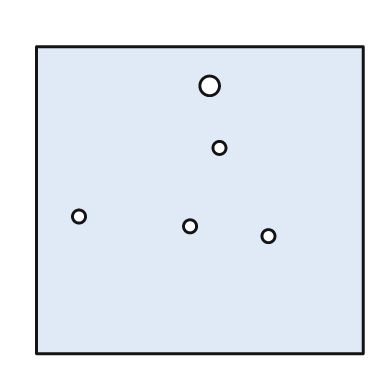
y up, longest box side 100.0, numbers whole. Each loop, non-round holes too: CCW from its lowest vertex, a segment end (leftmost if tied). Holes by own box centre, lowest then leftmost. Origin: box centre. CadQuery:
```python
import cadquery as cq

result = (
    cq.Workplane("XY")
    .moveTo(-50.0, -47.0)
    .lineTo(50.0, -47.0)
    .lineTo(50.0, 47.0)
    .lineTo(-50.0, 47.0)
    .close()
    .moveTo(21.0, -11.0)
    .circle(2.0)
    .moveTo(-3.0, -8.0)
    .circle(2.0)
    .moveTo(-37.0, -5.0)
    .circle(2.0)
    .moveTo(6.0, 16.0)
    .circle(2.0)
    .moveTo(3.0, 35.0)
    .circle(3.0)
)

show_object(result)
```